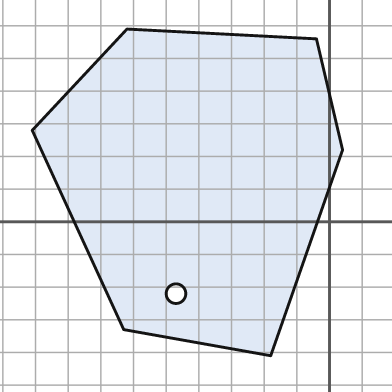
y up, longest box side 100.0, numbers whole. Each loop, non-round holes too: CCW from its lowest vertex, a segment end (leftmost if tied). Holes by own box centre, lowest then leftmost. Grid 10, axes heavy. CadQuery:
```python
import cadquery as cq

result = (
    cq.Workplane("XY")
    .moveTo(-18.0, -41.0)
    .lineTo(4.0, 22.0)
    .lineTo(-4.0, 56.0)
    .lineTo(-62.0, 59.0)
    .lineTo(-91.0, 28.0)
    .lineTo(-63.0, -33.0)
    .close()
    .moveTo(-47.0, -22.0)
    .circle(3.0)
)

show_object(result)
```